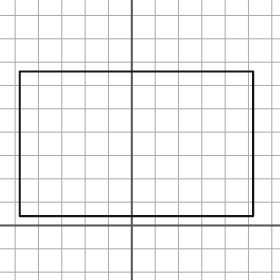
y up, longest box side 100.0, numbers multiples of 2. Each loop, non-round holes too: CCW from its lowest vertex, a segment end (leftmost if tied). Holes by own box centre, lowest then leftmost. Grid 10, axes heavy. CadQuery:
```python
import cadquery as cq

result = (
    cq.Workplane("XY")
    .moveTo(-48.0, 4.0)
    .lineTo(52.0, 4.0)
    .lineTo(52.0, 66.0)
    .lineTo(-48.0, 66.0)
    .close()
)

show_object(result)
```